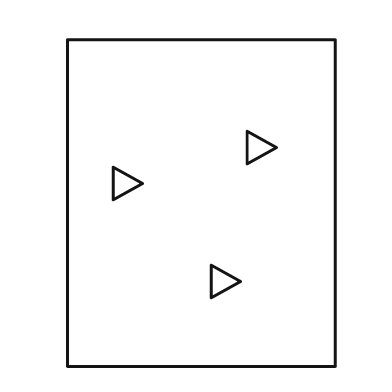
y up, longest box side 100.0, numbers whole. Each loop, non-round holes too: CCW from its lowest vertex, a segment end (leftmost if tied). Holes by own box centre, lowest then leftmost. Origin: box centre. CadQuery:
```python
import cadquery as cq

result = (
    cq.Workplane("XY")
    .moveTo(-41.0, -50.0)
    .lineTo(41.0, -50.0)
    .lineTo(41.0, 50.0)
    .lineTo(-41.0, 50.0)
    .close()
    .moveTo(3.0, -29.0)
    .lineTo(12.0, -24.0)
    .lineTo(3.0, -19.0)
    .close()
    .moveTo(-27.0, 1.0)
    .lineTo(-18.0, 6.0)
    .lineTo(-27.0, 11.0)
    .close()
    .moveTo(14.0, 12.0)
    .lineTo(23.0, 17.0)
    .lineTo(14.0, 22.0)
    .close()
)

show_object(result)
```